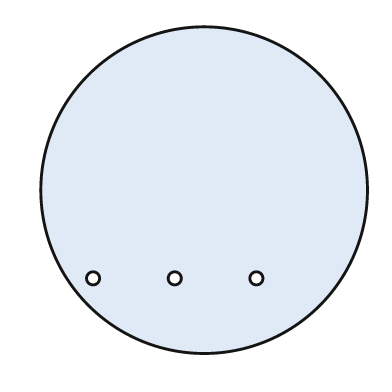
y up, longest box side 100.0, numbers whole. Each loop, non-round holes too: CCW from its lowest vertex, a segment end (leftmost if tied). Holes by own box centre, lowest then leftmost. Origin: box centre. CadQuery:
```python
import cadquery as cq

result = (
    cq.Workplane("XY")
    .moveTo(0.0, 0.0)
    .circle(50.0)
    .moveTo(-34.0, -27.0)
    .circle(2.0)
    .moveTo(-9.0, -27.0)
    .circle(2.0)
    .moveTo(16.0, -27.0)
    .circle(2.0)
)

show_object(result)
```